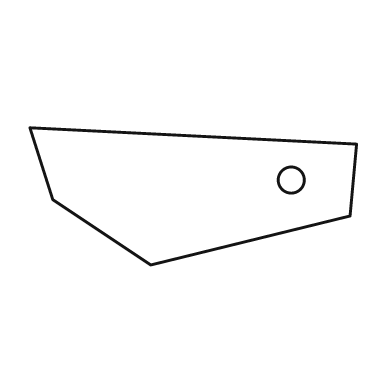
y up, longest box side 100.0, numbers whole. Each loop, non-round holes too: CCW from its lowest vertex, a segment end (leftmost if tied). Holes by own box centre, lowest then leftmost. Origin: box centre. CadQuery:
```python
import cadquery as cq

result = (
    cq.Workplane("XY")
    .moveTo(-13.0, -21.0)
    .lineTo(48.0, -6.0)
    .lineTo(50.0, 16.0)
    .lineTo(-50.0, 21.0)
    .lineTo(-43.0, -1.0)
    .close()
    .moveTo(30.0, 5.0)
    .circle(4.0)
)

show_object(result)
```